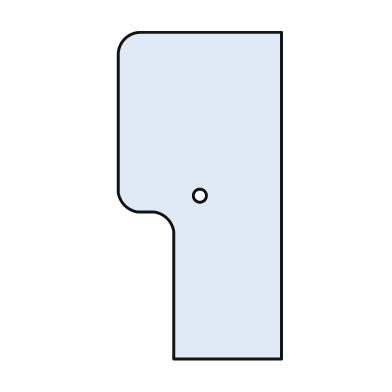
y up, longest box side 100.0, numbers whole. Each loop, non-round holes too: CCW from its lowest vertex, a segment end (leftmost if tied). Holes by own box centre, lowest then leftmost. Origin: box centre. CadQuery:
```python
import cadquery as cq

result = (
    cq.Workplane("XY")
    .moveTo(-8.0, -50.0)
    .lineTo(25.0, -50.0)
    .lineTo(25.0, 50.0)
    .lineTo(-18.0, 50.0)
    .threePointArc((-23.0, 48.0), (-25.0, 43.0))
    .lineTo(-25.0, 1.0)
    .threePointArc((-23.0, -3.0), (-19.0, -5.0))
    .lineTo(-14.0, -5.0)
    .threePointArc((-10.0, -7.0), (-8.0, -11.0))
    .close()
    .moveTo(0.0, 0.0)
    .circle(2.0)
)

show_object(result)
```